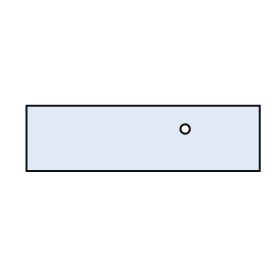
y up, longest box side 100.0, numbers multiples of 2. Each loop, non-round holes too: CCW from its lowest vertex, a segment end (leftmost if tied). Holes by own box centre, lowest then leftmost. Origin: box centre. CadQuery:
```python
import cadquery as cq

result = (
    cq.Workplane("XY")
    .moveTo(-50.0, -14.0)
    .lineTo(50.0, -14.0)
    .lineTo(50.0, 14.0)
    .lineTo(-50.0, 14.0)
    .close()
    .moveTo(18.0, 4.0)
    .circle(2.0)
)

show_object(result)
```